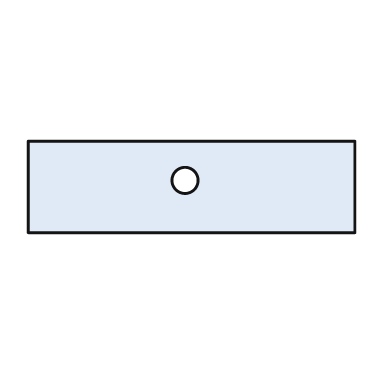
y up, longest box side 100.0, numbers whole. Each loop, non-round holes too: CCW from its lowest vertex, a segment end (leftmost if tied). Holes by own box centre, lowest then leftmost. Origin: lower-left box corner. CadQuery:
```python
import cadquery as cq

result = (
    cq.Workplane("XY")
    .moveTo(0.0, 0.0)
    .lineTo(100.0, 0.0)
    .lineTo(100.0, 28.0)
    .lineTo(0.0, 28.0)
    .close()
    .moveTo(48.0, 16.0)
    .circle(4.0)
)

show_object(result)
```